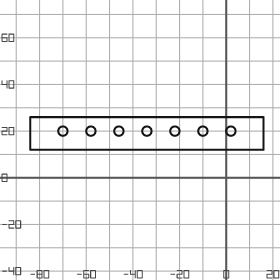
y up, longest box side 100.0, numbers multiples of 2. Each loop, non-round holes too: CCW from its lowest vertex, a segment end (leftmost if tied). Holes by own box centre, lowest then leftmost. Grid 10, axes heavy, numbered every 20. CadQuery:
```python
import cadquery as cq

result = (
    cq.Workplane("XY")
    .moveTo(-84.0, 12.0)
    .lineTo(16.0, 12.0)
    .lineTo(16.0, 26.0)
    .lineTo(-84.0, 26.0)
    .close()
    .moveTo(-70.0, 20.0)
    .circle(2.0)
    .moveTo(-58.0, 20.0)
    .circle(2.0)
    .moveTo(-46.0, 20.0)
    .circle(2.0)
    .moveTo(-34.0, 20.0)
    .circle(2.0)
    .moveTo(-22.0, 20.0)
    .circle(2.0)
    .moveTo(-10.0, 20.0)
    .circle(2.0)
    .moveTo(2.0, 20.0)
    .circle(2.0)
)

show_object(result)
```